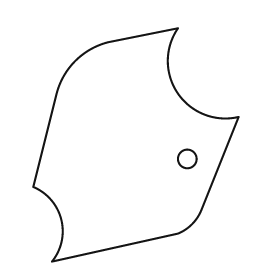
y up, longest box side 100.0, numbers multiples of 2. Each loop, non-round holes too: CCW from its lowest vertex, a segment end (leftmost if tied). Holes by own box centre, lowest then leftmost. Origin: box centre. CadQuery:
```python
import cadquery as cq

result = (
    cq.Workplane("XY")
    .moveTo(-36.0, -50.0)
    .lineTo(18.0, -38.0)
    .threePointArc((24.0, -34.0), (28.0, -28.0))
    .lineTo(44.0, 12.0)
    .threePointArc((18.0, 22.0), (18.0, 50.0))
    .lineTo(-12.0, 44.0)
    .threePointArc((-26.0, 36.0), (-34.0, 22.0))
    .lineTo(-44.0, -18.0)
    .threePointArc((-32.0, -32.0), (-36.0, -50.0))
    .close()
    .moveTo(22.0, -6.0)
    .circle(4.0)
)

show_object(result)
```